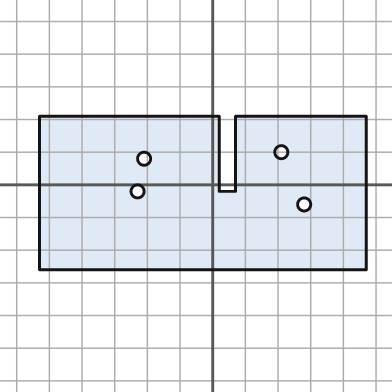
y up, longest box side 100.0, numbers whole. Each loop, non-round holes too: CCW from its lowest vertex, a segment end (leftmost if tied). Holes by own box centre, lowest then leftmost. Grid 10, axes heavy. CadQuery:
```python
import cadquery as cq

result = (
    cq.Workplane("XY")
    .moveTo(-53.0, -26.0)
    .lineTo(47.0, -26.0)
    .lineTo(47.0, 21.0)
    .lineTo(7.0, 21.0)
    .lineTo(7.0, -2.0)
    .lineTo(2.0, -2.0)
    .lineTo(2.0, 21.0)
    .lineTo(-53.0, 21.0)
    .close()
    .moveTo(28.0, -6.0)
    .circle(2.0)
    .moveTo(-23.0, -2.0)
    .circle(2.0)
    .moveTo(-21.0, 8.0)
    .circle(2.0)
    .moveTo(21.0, 10.0)
    .circle(2.0)
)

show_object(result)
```